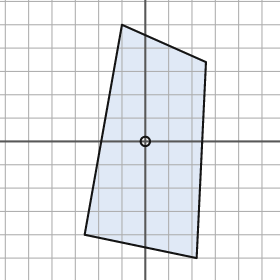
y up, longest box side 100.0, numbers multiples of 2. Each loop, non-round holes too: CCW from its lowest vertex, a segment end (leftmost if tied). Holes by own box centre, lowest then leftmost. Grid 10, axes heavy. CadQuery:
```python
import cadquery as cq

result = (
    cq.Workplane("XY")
    .moveTo(22.0, -50.0)
    .lineTo(26.0, 34.0)
    .lineTo(-10.0, 50.0)
    .lineTo(-26.0, -40.0)
    .close()
    .moveTo(0.0, 0.0)
    .circle(2.0)
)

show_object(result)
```